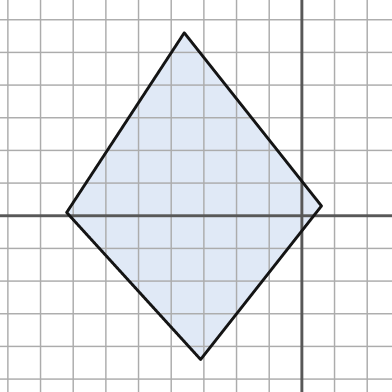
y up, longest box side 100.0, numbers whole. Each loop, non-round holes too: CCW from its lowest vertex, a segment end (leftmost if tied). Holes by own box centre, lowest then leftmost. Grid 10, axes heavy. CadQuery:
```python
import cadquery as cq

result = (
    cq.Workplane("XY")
    .moveTo(-31.0, -44.0)
    .lineTo(6.0, 3.0)
    .lineTo(-36.0, 56.0)
    .lineTo(-72.0, 1.0)
    .close()
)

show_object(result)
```